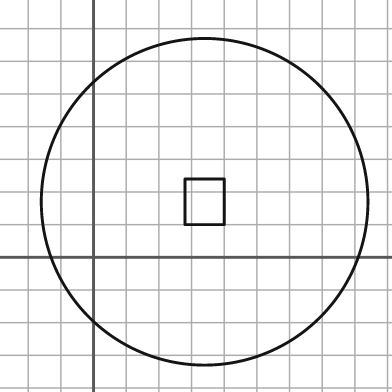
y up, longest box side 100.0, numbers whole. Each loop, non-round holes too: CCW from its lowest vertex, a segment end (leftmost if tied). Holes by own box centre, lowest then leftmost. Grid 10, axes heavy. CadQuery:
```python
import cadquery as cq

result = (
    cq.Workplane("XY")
    .moveTo(34.0, 17.0)
    .circle(50.0)
    .moveTo(28.0, 10.0)
    .lineTo(40.0, 10.0)
    .lineTo(40.0, 24.0)
    .lineTo(28.0, 24.0)
    .close()
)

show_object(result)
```